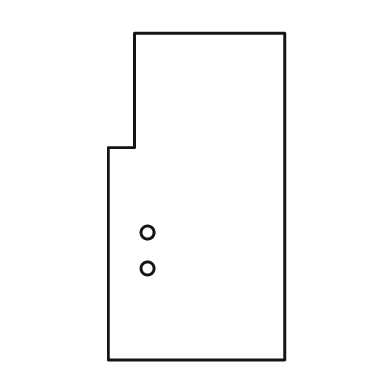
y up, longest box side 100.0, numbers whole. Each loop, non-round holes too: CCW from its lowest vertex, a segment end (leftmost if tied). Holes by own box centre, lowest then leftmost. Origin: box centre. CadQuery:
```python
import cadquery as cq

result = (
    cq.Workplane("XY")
    .moveTo(-27.0, -50.0)
    .lineTo(27.0, -50.0)
    .lineTo(27.0, 50.0)
    .lineTo(-19.0, 50.0)
    .lineTo(-19.0, 15.0)
    .lineTo(-27.0, 15.0)
    .close()
    .moveTo(-15.0, -22.0)
    .circle(2.0)
    .moveTo(-15.0, -11.0)
    .circle(2.0)
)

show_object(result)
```